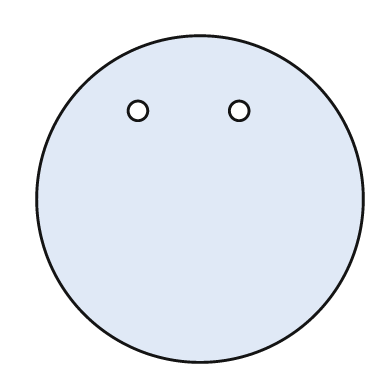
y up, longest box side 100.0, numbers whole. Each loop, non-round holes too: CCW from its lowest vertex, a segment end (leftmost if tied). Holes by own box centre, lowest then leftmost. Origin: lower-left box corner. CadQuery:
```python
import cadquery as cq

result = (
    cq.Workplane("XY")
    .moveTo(50.0, 50.0)
    .circle(50.0)
    .moveTo(31.0, 77.0)
    .circle(3.0)
    .moveTo(62.0, 77.0)
    .circle(3.0)
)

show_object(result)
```